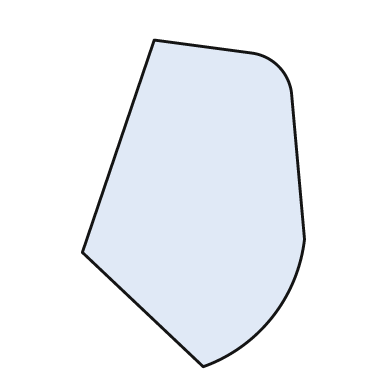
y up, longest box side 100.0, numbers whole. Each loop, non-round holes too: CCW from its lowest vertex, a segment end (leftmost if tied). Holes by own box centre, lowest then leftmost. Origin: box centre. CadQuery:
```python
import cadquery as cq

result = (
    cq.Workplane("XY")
    .moveTo(3.0, -50.0)
    .threePointArc((24.0, -35.0), (34.0, -11.0))
    .lineTo(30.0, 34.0)
    .threePointArc((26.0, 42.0), (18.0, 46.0))
    .lineTo(-12.0, 50.0)
    .lineTo(-34.0, -15.0)
    .close()
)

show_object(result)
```